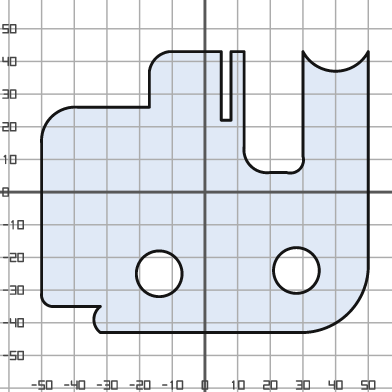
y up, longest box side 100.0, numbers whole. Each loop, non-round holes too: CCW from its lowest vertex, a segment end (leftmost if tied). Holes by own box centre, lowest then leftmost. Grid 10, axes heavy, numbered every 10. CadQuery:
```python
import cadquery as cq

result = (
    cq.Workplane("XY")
    .moveTo(-32.0, -43.0)
    .lineTo(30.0, -43.0)
    .threePointArc((44.0, -37.0), (50.0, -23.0))
    .lineTo(50.0, 43.0)
    .threePointArc((40.0, 37.0), (30.0, 43.0))
    .lineTo(30.0, 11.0)
    .threePointArc((29.0, 7.0), (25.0, 6.0))
    .lineTo(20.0, 6.0)
    .threePointArc((14.0, 8.0), (12.0, 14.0))
    .lineTo(12.0, 43.0)
    .lineTo(8.0, 43.0)
    .lineTo(8.0, 22.0)
    .lineTo(5.0, 22.0)
    .lineTo(5.0, 43.0)
    .lineTo(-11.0, 43.0)
    .threePointArc((-15.0, 41.0), (-17.0, 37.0))
    .lineTo(-17.0, 26.0)
    .lineTo(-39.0, 26.0)
    .threePointArc((-47.0, 23.0), (-50.0, 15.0))
    .lineTo(-50.0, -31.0)
    .threePointArc((-49.0, -34.0), (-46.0, -35.0))
    .lineTo(-32.0, -35.0)
    .threePointArc((-34.0, -39.0), (-32.0, -43.0))
    .close()
    .moveTo(-14.0, -25.0)
    .circle(7.0)
    .moveTo(28.0, -24.0)
    .circle(7.0)
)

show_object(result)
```